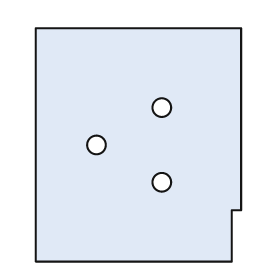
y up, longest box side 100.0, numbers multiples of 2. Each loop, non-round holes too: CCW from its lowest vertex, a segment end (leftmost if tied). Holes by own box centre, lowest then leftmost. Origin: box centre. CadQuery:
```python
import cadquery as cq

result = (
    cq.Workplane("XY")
    .moveTo(-44.0, -50.0)
    .lineTo(40.0, -50.0)
    .lineTo(40.0, -28.0)
    .lineTo(44.0, -28.0)
    .lineTo(44.0, 50.0)
    .lineTo(-44.0, 50.0)
    .close()
    .moveTo(10.0, -16.0)
    .circle(4.0)
    .moveTo(-18.0, 0.0)
    .circle(4.0)
    .moveTo(10.0, 16.0)
    .circle(4.0)
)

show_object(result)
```